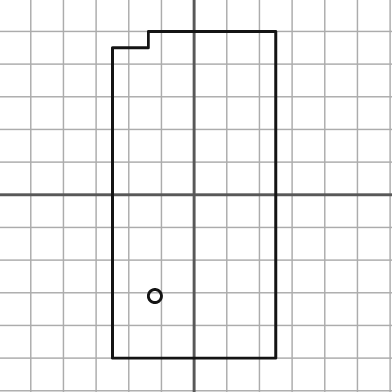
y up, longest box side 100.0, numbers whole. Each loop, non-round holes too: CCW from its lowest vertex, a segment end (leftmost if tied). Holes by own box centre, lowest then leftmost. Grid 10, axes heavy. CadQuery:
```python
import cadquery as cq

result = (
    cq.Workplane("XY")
    .moveTo(-25.0, -50.0)
    .lineTo(25.0, -50.0)
    .lineTo(25.0, 50.0)
    .lineTo(-14.0, 50.0)
    .lineTo(-14.0, 45.0)
    .lineTo(-25.0, 45.0)
    .close()
    .moveTo(-12.0, -31.0)
    .circle(2.0)
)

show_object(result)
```